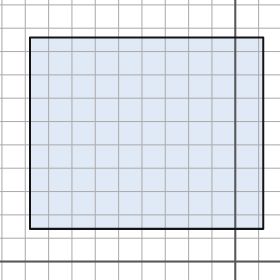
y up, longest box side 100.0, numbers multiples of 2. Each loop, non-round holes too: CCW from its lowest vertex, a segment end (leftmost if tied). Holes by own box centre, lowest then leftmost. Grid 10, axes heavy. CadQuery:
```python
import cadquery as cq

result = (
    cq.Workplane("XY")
    .moveTo(-88.0, 14.0)
    .lineTo(12.0, 14.0)
    .lineTo(12.0, 96.0)
    .lineTo(-88.0, 96.0)
    .close()
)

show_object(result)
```